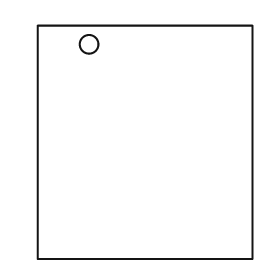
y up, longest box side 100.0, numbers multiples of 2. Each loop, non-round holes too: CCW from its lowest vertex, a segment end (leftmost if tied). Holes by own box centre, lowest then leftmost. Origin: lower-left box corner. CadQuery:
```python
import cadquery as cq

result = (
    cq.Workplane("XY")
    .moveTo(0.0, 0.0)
    .lineTo(92.0, 0.0)
    .lineTo(92.0, 100.0)
    .lineTo(0.0, 100.0)
    .close()
    .moveTo(22.0, 92.0)
    .circle(4.0)
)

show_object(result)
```